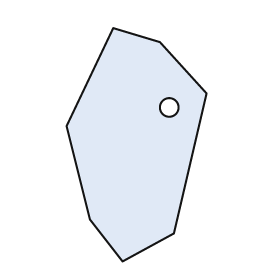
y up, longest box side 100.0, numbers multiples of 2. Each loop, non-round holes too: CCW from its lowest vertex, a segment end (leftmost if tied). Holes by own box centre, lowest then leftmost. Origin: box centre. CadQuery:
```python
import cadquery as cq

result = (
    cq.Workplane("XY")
    .moveTo(-6.0, -50.0)
    .lineTo(16.0, -38.0)
    .lineTo(30.0, 22.0)
    .lineTo(10.0, 44.0)
    .lineTo(-10.0, 50.0)
    .lineTo(-30.0, 8.0)
    .lineTo(-20.0, -32.0)
    .close()
    .moveTo(14.0, 16.0)
    .circle(4.0)
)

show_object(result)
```